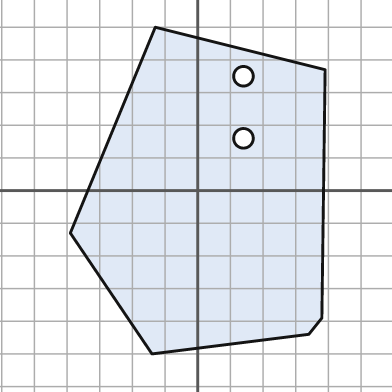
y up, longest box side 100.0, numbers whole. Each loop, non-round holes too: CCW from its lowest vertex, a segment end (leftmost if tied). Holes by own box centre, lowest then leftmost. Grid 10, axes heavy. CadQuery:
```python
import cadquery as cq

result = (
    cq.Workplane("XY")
    .moveTo(-14.0, -50.0)
    .lineTo(34.0, -44.0)
    .lineTo(38.0, -39.0)
    .lineTo(39.0, 37.0)
    .lineTo(-13.0, 50.0)
    .lineTo(-39.0, -13.0)
    .close()
    .moveTo(14.0, 16.0)
    .circle(3.0)
    .moveTo(14.0, 35.0)
    .circle(3.0)
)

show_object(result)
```